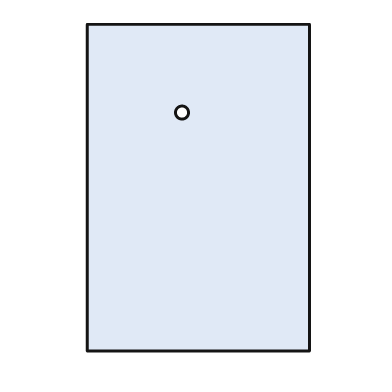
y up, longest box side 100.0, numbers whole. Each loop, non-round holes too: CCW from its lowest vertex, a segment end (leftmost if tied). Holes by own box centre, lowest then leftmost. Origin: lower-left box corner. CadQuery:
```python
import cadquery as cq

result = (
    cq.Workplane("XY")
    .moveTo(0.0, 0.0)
    .lineTo(68.0, 0.0)
    .lineTo(68.0, 100.0)
    .lineTo(0.0, 100.0)
    .close()
    .moveTo(29.0, 73.0)
    .circle(2.0)
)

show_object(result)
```